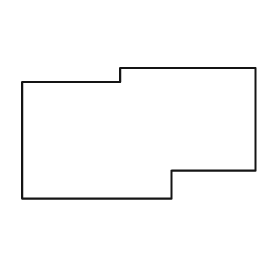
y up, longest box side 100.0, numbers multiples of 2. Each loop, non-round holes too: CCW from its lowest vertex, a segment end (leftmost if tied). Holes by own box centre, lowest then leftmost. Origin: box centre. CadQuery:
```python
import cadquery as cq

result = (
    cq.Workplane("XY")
    .moveTo(-50.0, -28.0)
    .lineTo(14.0, -28.0)
    .lineTo(14.0, -16.0)
    .lineTo(50.0, -16.0)
    .lineTo(50.0, 28.0)
    .lineTo(-8.0, 28.0)
    .lineTo(-8.0, 22.0)
    .lineTo(-50.0, 22.0)
    .close()
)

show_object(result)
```